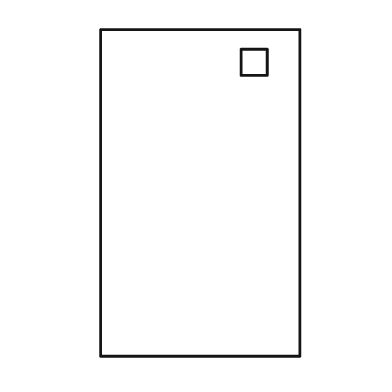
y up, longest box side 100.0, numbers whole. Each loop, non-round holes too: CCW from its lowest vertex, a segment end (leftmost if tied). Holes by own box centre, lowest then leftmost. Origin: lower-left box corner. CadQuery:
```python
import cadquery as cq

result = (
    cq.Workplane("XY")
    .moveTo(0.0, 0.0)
    .lineTo(61.0, 0.0)
    .lineTo(61.0, 100.0)
    .lineTo(0.0, 100.0)
    .close()
    .moveTo(43.0, 86.0)
    .lineTo(51.0, 86.0)
    .lineTo(51.0, 94.0)
    .lineTo(43.0, 94.0)
    .close()
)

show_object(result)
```